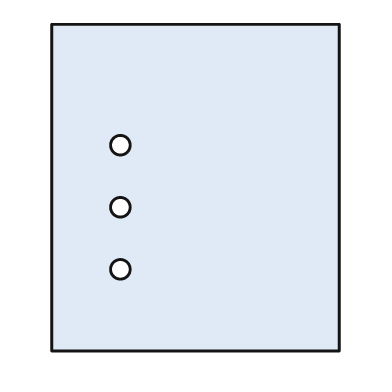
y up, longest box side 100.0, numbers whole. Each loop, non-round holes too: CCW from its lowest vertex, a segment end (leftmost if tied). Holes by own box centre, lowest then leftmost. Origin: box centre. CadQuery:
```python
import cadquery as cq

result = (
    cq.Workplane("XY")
    .moveTo(-44.0, -50.0)
    .lineTo(44.0, -50.0)
    .lineTo(44.0, 50.0)
    .lineTo(-44.0, 50.0)
    .close()
    .moveTo(-23.0, -25.0)
    .circle(3.0)
    .moveTo(-23.0, -6.0)
    .circle(3.0)
    .moveTo(-23.0, 13.0)
    .circle(3.0)
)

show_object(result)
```